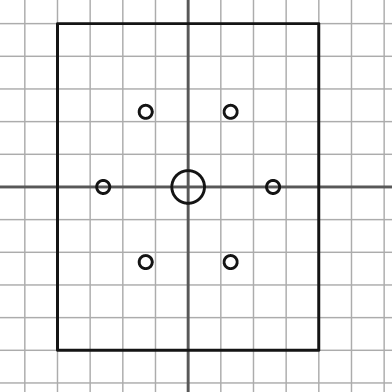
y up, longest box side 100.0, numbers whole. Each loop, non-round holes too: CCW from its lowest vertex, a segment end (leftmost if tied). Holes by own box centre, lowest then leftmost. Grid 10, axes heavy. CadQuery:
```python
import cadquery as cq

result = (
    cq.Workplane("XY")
    .moveTo(-40.0, -50.0)
    .lineTo(40.0, -50.0)
    .lineTo(40.0, 50.0)
    .lineTo(-40.0, 50.0)
    .close()
    .moveTo(-13.0, -23.0)
    .circle(2.0)
    .moveTo(13.0, -23.0)
    .circle(2.0)
    .moveTo(-26.0, 0.0)
    .circle(2.0)
    .moveTo(0.0, 0.0)
    .circle(5.0)
    .moveTo(26.0, 0.0)
    .circle(2.0)
    .moveTo(-13.0, 23.0)
    .circle(2.0)
    .moveTo(13.0, 23.0)
    .circle(2.0)
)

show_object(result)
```